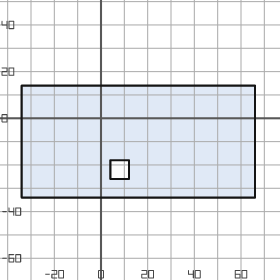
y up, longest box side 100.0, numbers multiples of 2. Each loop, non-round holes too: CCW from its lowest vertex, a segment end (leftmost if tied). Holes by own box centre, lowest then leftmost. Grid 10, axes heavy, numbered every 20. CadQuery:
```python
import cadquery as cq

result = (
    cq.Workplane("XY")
    .moveTo(-34.0, -34.0)
    .lineTo(66.0, -34.0)
    .lineTo(66.0, 14.0)
    .lineTo(-34.0, 14.0)
    .close()
    .moveTo(4.0, -26.0)
    .lineTo(12.0, -26.0)
    .lineTo(12.0, -18.0)
    .lineTo(4.0, -18.0)
    .close()
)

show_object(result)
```